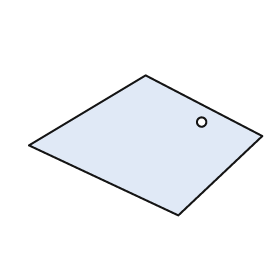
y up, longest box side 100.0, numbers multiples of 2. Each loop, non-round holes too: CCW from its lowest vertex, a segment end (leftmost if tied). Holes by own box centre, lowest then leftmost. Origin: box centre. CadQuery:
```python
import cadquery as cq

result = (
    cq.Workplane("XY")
    .moveTo(14.0, -30.0)
    .lineTo(50.0, 4.0)
    .lineTo(0.0, 30.0)
    .lineTo(-50.0, 0.0)
    .close()
    .moveTo(24.0, 10.0)
    .circle(2.0)
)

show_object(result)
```